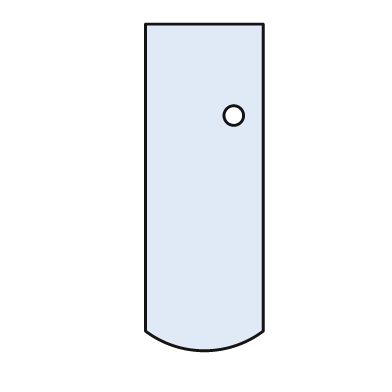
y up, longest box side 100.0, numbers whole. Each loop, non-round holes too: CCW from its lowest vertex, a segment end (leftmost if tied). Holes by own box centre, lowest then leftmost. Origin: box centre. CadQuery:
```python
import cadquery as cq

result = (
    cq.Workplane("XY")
    .moveTo(-18.0, -44.0)
    .threePointArc((0.0, -50.0), (18.0, -44.0))
    .lineTo(18.0, 50.0)
    .lineTo(-18.0, 50.0)
    .close()
    .moveTo(9.0, 22.0)
    .circle(3.0)
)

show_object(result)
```